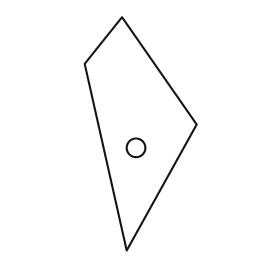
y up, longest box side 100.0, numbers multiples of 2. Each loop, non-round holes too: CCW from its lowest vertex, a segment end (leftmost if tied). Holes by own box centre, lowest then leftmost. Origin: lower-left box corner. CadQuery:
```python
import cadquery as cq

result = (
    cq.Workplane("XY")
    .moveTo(18.0, 0.0)
    .lineTo(48.0, 54.0)
    .lineTo(16.0, 100.0)
    .lineTo(0.0, 80.0)
    .close()
    .moveTo(22.0, 44.0)
    .circle(4.0)
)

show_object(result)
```